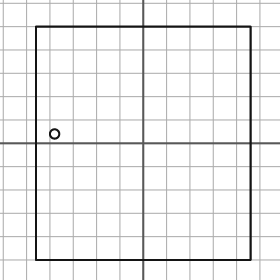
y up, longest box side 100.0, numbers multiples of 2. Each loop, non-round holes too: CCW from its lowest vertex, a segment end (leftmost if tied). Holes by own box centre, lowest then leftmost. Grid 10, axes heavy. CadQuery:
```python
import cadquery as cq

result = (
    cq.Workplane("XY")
    .moveTo(-46.0, -50.0)
    .lineTo(46.0, -50.0)
    .lineTo(46.0, 50.0)
    .lineTo(-46.0, 50.0)
    .close()
    .moveTo(-38.0, 4.0)
    .circle(2.0)
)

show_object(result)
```